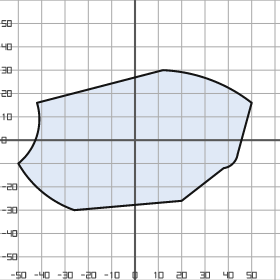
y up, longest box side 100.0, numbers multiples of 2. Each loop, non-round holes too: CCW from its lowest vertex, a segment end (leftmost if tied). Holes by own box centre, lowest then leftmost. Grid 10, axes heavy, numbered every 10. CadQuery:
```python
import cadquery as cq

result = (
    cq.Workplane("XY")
    .moveTo(-26.0, -30.0)
    .lineTo(20.0, -26.0)
    .lineTo(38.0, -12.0)
    .threePointArc((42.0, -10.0), (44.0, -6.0))
    .lineTo(50.0, 16.0)
    .threePointArc((32.0, 26.0), (12.0, 30.0))
    .lineTo(-42.0, 16.0)
    .threePointArc((-42.0, 2.0), (-50.0, -10.0))
    .threePointArc((-40.0, -22.0), (-26.0, -30.0))
    .close()
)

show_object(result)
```